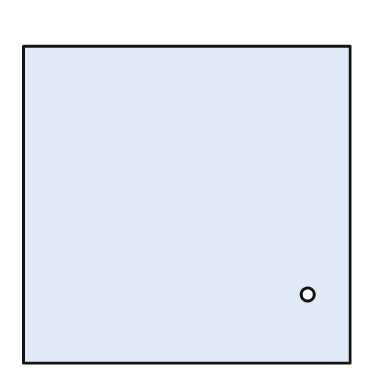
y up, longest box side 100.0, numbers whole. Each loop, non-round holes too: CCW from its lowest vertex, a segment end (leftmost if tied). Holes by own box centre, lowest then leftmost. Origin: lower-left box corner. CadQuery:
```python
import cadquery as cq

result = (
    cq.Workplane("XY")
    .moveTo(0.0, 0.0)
    .lineTo(100.0, 0.0)
    .lineTo(100.0, 97.0)
    .lineTo(0.0, 97.0)
    .close()
    .moveTo(87.0, 21.0)
    .circle(2.0)
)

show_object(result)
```